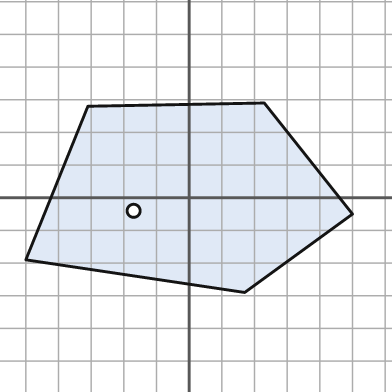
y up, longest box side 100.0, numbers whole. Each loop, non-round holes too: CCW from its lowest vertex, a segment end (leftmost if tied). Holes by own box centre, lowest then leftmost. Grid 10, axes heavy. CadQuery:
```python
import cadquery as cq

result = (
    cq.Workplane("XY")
    .moveTo(17.0, -29.0)
    .lineTo(50.0, -5.0)
    .lineTo(23.0, 29.0)
    .lineTo(-31.0, 28.0)
    .lineTo(-50.0, -19.0)
    .close()
    .moveTo(-17.0, -4.0)
    .circle(2.0)
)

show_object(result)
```